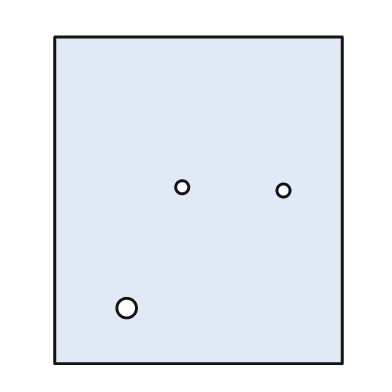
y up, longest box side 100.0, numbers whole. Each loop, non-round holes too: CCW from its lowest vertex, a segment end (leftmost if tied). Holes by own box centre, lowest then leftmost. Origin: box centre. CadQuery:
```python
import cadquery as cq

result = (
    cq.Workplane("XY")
    .moveTo(-44.0, -50.0)
    .lineTo(44.0, -50.0)
    .lineTo(44.0, 50.0)
    .lineTo(-44.0, 50.0)
    .close()
    .moveTo(-22.0, -33.0)
    .circle(3.0)
    .moveTo(26.0, 3.0)
    .circle(2.0)
    .moveTo(-5.0, 4.0)
    .circle(2.0)
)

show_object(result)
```